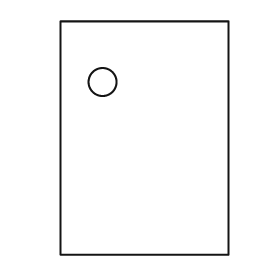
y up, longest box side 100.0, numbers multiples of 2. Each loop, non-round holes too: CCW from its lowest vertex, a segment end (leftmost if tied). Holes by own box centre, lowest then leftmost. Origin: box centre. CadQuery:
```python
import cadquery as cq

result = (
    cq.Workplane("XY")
    .moveTo(-36.0, -50.0)
    .lineTo(36.0, -50.0)
    .lineTo(36.0, 50.0)
    .lineTo(-36.0, 50.0)
    .close()
    .moveTo(-18.0, 24.0)
    .circle(6.0)
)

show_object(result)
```